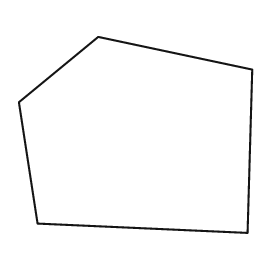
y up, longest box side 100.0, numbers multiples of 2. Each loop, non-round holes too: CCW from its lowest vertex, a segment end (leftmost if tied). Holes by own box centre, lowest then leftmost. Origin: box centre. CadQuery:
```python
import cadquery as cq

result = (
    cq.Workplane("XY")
    .moveTo(48.0, -42.0)
    .lineTo(50.0, 28.0)
    .lineTo(-16.0, 42.0)
    .lineTo(-50.0, 14.0)
    .lineTo(-42.0, -38.0)
    .close()
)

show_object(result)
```